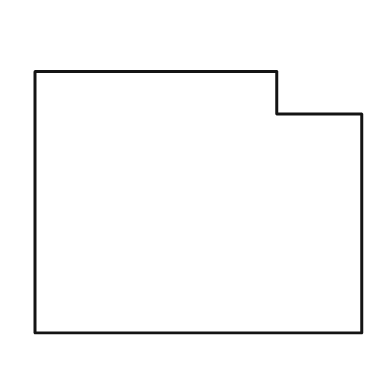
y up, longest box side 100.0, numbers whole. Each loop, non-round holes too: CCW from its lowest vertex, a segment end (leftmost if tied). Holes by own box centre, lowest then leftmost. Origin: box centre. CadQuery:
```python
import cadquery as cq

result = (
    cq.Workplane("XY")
    .moveTo(-50.0, -40.0)
    .lineTo(50.0, -40.0)
    .lineTo(50.0, 27.0)
    .lineTo(24.0, 27.0)
    .lineTo(24.0, 40.0)
    .lineTo(-50.0, 40.0)
    .close()
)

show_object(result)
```